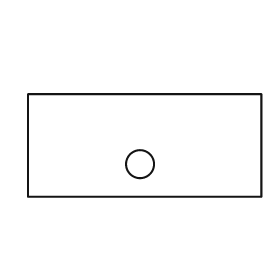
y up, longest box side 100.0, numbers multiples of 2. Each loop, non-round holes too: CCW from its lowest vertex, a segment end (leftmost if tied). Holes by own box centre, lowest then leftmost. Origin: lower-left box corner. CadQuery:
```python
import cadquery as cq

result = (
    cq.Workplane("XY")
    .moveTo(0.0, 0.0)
    .lineTo(100.0, 0.0)
    .lineTo(100.0, 44.0)
    .lineTo(0.0, 44.0)
    .close()
    .moveTo(48.0, 14.0)
    .circle(6.0)
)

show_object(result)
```